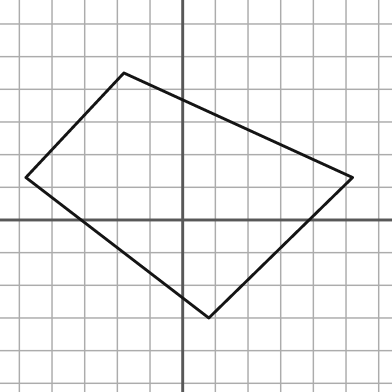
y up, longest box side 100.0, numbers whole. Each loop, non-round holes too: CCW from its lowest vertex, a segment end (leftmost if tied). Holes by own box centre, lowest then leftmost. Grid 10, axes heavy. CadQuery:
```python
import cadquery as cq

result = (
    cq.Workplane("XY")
    .moveTo(8.0, -30.0)
    .lineTo(52.0, 13.0)
    .lineTo(-18.0, 45.0)
    .lineTo(-48.0, 13.0)
    .close()
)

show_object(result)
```